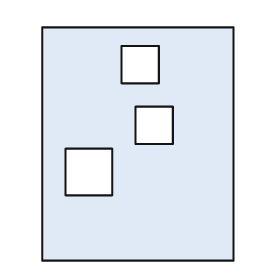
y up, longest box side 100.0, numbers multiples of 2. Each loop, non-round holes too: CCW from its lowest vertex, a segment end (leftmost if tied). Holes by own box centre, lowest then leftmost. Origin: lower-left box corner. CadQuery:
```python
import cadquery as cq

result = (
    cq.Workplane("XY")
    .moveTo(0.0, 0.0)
    .lineTo(82.0, 0.0)
    .lineTo(82.0, 100.0)
    .lineTo(0.0, 100.0)
    .close()
    .moveTo(10.0, 28.0)
    .lineTo(30.0, 28.0)
    .lineTo(30.0, 48.0)
    .lineTo(10.0, 48.0)
    .close()
    .moveTo(40.0, 50.0)
    .lineTo(56.0, 50.0)
    .lineTo(56.0, 66.0)
    .lineTo(40.0, 66.0)
    .close()
    .moveTo(34.0, 76.0)
    .lineTo(50.0, 76.0)
    .lineTo(50.0, 92.0)
    .lineTo(34.0, 92.0)
    .close()
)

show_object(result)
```